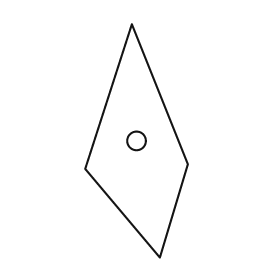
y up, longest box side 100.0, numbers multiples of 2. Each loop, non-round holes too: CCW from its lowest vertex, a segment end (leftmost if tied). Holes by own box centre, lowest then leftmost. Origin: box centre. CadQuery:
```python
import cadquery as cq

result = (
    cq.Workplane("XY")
    .moveTo(10.0, -50.0)
    .lineTo(22.0, -10.0)
    .lineTo(-2.0, 50.0)
    .lineTo(-22.0, -12.0)
    .close()
    .moveTo(0.0, 0.0)
    .circle(4.0)
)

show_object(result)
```